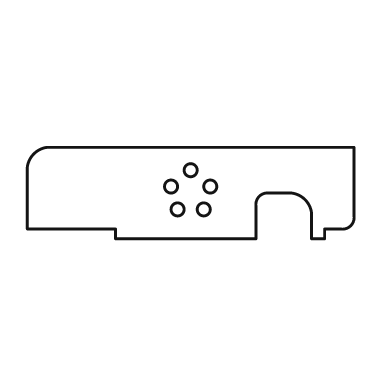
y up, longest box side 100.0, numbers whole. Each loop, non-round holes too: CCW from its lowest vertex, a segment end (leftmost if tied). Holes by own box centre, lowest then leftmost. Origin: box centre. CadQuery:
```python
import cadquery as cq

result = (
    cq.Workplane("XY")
    .moveTo(-23.0, -14.0)
    .lineTo(20.0, -14.0)
    .lineTo(20.0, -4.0)
    .threePointArc((21.0, -1.0), (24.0, 0.0))
    .lineTo(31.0, 0.0)
    .threePointArc((35.0, -2.0), (37.0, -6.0))
    .lineTo(37.0, -14.0)
    .lineTo(41.0, -14.0)
    .lineTo(41.0, -11.0)
    .lineTo(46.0, -11.0)
    .threePointArc((49.0, -10.0), (50.0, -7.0))
    .lineTo(50.0, 14.0)
    .lineTo(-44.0, 14.0)
    .threePointArc((-48.0, 12.0), (-50.0, 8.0))
    .lineTo(-50.0, -11.0)
    .lineTo(-23.0, -11.0)
    .close()
    .moveTo(-4.0, -5.0)
    .circle(2.0)
    .moveTo(4.0, -5.0)
    .circle(2.0)
    .moveTo(-6.0, 2.0)
    .circle(2.0)
    .moveTo(6.0, 2.0)
    .circle(2.0)
    .moveTo(0.0, 7.0)
    .circle(2.0)
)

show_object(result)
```